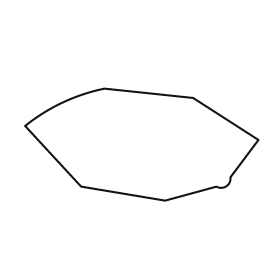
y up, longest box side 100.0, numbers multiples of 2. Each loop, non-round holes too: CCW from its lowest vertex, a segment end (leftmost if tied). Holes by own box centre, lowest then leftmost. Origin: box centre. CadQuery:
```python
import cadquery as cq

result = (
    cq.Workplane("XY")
    .moveTo(10.0, -24.0)
    .lineTo(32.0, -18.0)
    .threePointArc((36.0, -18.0), (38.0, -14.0))
    .lineTo(50.0, 2.0)
    .lineTo(22.0, 20.0)
    .lineTo(-16.0, 24.0)
    .threePointArc((-34.0, 18.0), (-50.0, 8.0))
    .lineTo(-26.0, -18.0)
    .close()
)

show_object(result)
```